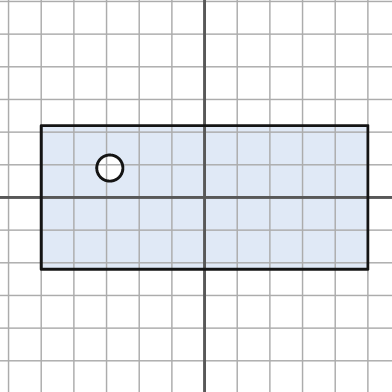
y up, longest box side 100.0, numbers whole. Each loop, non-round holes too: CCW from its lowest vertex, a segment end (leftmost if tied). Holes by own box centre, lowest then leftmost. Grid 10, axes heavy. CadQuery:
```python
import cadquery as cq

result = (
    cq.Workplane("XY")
    .moveTo(-50.0, -22.0)
    .lineTo(50.0, -22.0)
    .lineTo(50.0, 22.0)
    .lineTo(-50.0, 22.0)
    .close()
    .moveTo(-29.0, 9.0)
    .circle(4.0)
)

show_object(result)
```